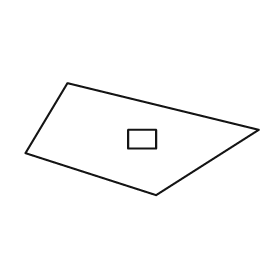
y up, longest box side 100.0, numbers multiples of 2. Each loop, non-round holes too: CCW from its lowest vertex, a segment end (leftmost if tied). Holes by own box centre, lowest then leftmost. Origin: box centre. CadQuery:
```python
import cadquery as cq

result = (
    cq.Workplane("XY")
    .moveTo(6.0, -24.0)
    .lineTo(50.0, 4.0)
    .lineTo(-32.0, 24.0)
    .lineTo(-50.0, -6.0)
    .close()
    .moveTo(-6.0, -4.0)
    .lineTo(6.0, -4.0)
    .lineTo(6.0, 4.0)
    .lineTo(-6.0, 4.0)
    .close()
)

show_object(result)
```